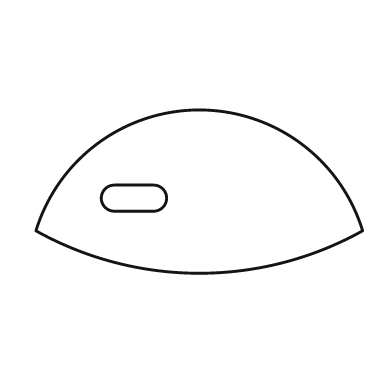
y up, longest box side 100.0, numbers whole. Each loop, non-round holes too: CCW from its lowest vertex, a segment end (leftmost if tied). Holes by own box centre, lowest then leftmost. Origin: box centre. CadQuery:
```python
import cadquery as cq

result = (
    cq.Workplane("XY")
    .moveTo(-50.0, -12.0)
    .threePointArc((0.0, -25.0), (50.0, -12.0))
    .threePointArc((0.0, 25.0), (-50.0, -12.0))
    .close()
    .moveTo(-26.0, -6.0)
    .lineTo(-14.0, -6.0)
    .threePointArc((-10.0, -2.0), (-14.0, 2.0))
    .lineTo(-26.0, 2.0)
    .threePointArc((-30.0, -2.0), (-26.0, -6.0))
    .close()
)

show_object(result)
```